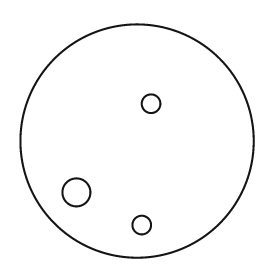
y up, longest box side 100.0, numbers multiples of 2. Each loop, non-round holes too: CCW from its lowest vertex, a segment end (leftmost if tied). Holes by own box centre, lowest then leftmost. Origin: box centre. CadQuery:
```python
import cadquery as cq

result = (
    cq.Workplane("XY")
    .moveTo(0.0, 0.0)
    .circle(50.0)
    .moveTo(2.0, -36.0)
    .circle(4.0)
    .moveTo(-26.0, -22.0)
    .circle(6.0)
    .moveTo(6.0, 16.0)
    .circle(4.0)
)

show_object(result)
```